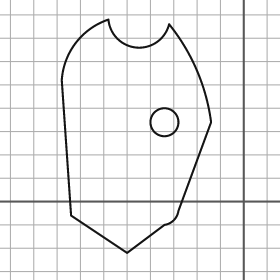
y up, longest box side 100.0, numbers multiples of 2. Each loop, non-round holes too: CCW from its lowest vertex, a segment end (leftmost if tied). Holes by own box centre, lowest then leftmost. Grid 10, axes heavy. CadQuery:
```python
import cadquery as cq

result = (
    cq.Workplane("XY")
    .moveTo(-50.0, -22.0)
    .lineTo(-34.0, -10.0)
    .threePointArc((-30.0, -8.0), (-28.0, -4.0))
    .lineTo(-14.0, 34.0)
    .threePointArc((-20.0, 56.0), (-32.0, 76.0))
    .threePointArc((-46.0, 66.0), (-58.0, 78.0))
    .threePointArc((-72.0, 68.0), (-78.0, 52.0))
    .lineTo(-74.0, -6.0)
    .close()
    .moveTo(-34.0, 34.0)
    .circle(6.0)
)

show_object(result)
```